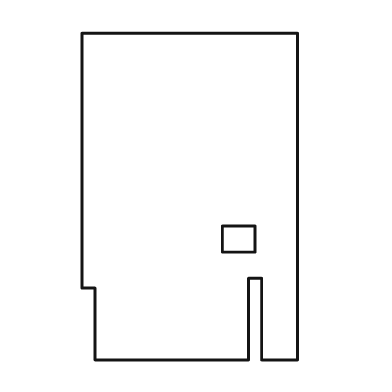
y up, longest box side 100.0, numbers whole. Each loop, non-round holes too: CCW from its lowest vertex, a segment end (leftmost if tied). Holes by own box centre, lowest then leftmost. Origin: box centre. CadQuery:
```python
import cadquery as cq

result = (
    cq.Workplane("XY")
    .moveTo(-29.0, -50.0)
    .lineTo(18.0, -50.0)
    .lineTo(18.0, -25.0)
    .lineTo(22.0, -25.0)
    .lineTo(22.0, -50.0)
    .lineTo(33.0, -50.0)
    .lineTo(33.0, 50.0)
    .lineTo(-33.0, 50.0)
    .lineTo(-33.0, -28.0)
    .lineTo(-29.0, -28.0)
    .close()
    .moveTo(10.0, -17.0)
    .lineTo(20.0, -17.0)
    .lineTo(20.0, -9.0)
    .lineTo(10.0, -9.0)
    .close()
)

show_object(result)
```